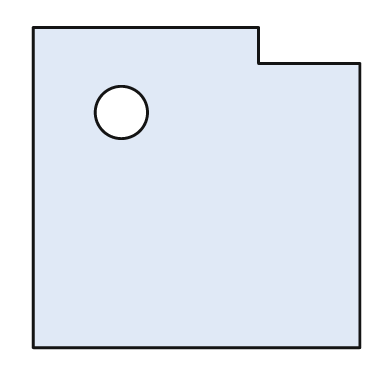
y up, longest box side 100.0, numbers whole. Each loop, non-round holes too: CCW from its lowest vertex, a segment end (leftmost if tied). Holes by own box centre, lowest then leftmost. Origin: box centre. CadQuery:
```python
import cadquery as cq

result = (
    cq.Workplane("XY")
    .moveTo(-50.0, -49.0)
    .lineTo(50.0, -49.0)
    .lineTo(50.0, 38.0)
    .lineTo(19.0, 38.0)
    .lineTo(19.0, 49.0)
    .lineTo(-50.0, 49.0)
    .close()
    .moveTo(-23.0, 23.0)
    .circle(8.0)
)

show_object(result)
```